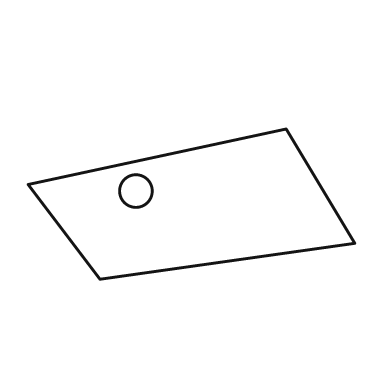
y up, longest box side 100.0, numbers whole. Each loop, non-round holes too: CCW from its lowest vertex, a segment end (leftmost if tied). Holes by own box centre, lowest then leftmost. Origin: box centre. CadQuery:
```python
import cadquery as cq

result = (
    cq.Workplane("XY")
    .moveTo(-28.0, -23.0)
    .lineTo(50.0, -12.0)
    .lineTo(29.0, 23.0)
    .lineTo(-50.0, 6.0)
    .close()
    .moveTo(-17.0, 4.0)
    .circle(5.0)
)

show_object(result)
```